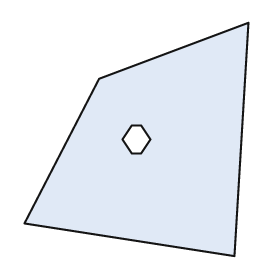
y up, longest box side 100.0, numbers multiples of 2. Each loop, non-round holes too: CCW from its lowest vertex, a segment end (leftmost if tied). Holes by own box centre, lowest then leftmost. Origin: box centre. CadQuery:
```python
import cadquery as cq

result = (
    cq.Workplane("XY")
    .moveTo(42.0, -50.0)
    .lineTo(48.0, 50.0)
    .lineTo(-16.0, 26.0)
    .lineTo(-48.0, -36.0)
    .close()
    .moveTo(-2.0, -6.0)
    .lineTo(2.0, -6.0)
    .lineTo(6.0, 0.0)
    .lineTo(2.0, 6.0)
    .lineTo(-2.0, 6.0)
    .lineTo(-6.0, 0.0)
    .close()
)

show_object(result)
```